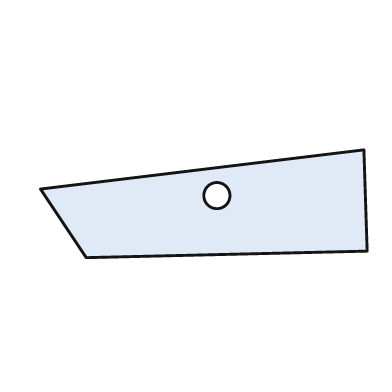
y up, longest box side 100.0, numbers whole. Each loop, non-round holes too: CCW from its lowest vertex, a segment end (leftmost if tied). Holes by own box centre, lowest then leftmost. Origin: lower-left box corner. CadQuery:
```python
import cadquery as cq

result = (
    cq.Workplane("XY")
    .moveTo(14.0, 0.0)
    .lineTo(100.0, 2.0)
    .lineTo(99.0, 33.0)
    .lineTo(0.0, 21.0)
    .close()
    .moveTo(54.0, 19.0)
    .circle(4.0)
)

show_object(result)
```